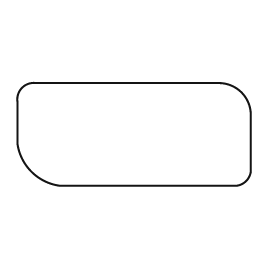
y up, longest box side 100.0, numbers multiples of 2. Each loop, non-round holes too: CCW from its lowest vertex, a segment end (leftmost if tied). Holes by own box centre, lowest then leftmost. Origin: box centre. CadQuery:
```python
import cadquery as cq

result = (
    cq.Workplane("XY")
    .moveTo(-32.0, -22.0)
    .lineTo(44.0, -22.0)
    .threePointArc((48.0, -20.0), (50.0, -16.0))
    .lineTo(50.0, 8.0)
    .threePointArc((46.0, 18.0), (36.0, 22.0))
    .lineTo(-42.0, 22.0)
    .threePointArc((-48.0, 20.0), (-50.0, 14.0))
    .lineTo(-50.0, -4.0)
    .threePointArc((-44.0, -16.0), (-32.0, -22.0))
    .close()
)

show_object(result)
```